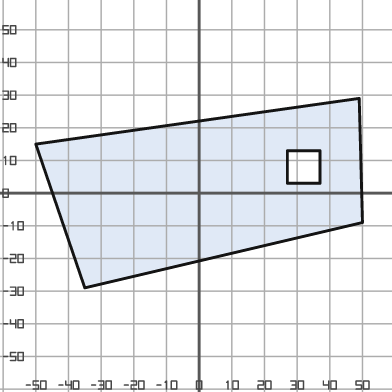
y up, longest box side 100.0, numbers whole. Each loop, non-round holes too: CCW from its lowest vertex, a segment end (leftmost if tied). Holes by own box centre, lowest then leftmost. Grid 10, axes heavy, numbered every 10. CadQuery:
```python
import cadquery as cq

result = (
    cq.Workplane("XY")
    .moveTo(-35.0, -29.0)
    .lineTo(50.0, -9.0)
    .lineTo(49.0, 29.0)
    .lineTo(-50.0, 15.0)
    .close()
    .moveTo(27.0, 3.0)
    .lineTo(37.0, 3.0)
    .lineTo(37.0, 13.0)
    .lineTo(27.0, 13.0)
    .close()
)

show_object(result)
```